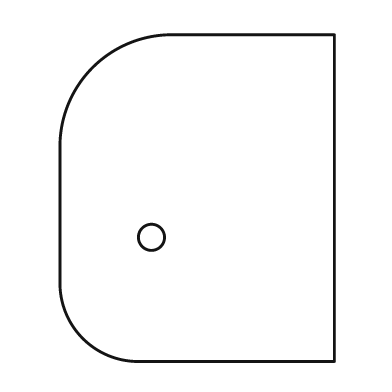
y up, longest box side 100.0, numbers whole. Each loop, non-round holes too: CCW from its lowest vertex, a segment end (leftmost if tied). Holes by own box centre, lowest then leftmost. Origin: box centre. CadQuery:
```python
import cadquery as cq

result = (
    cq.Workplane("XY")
    .moveTo(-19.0, -50.0)
    .lineTo(42.0, -50.0)
    .lineTo(42.0, 50.0)
    .lineTo(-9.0, 50.0)
    .threePointArc((-32.0, 40.0), (-42.0, 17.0))
    .lineTo(-42.0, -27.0)
    .threePointArc((-35.0, -43.0), (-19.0, -50.0))
    .close()
    .moveTo(-14.0, -12.0)
    .circle(4.0)
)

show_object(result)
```